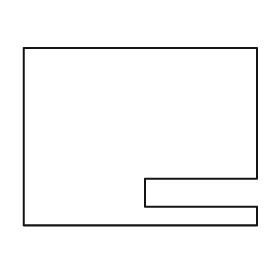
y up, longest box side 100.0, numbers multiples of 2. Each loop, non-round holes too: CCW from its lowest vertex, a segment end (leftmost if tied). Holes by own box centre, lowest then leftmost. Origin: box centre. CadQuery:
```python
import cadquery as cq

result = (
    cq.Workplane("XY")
    .moveTo(-50.0, -38.0)
    .lineTo(50.0, -38.0)
    .lineTo(50.0, -30.0)
    .lineTo(2.0, -30.0)
    .lineTo(2.0, -18.0)
    .lineTo(50.0, -18.0)
    .lineTo(50.0, 38.0)
    .lineTo(-50.0, 38.0)
    .close()
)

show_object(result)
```